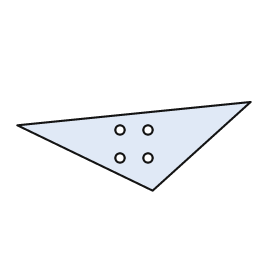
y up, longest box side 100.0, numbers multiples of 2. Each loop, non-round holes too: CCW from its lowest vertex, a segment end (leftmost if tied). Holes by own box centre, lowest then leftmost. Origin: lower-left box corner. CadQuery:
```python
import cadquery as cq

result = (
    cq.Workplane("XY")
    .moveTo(58.0, 0.0)
    .lineTo(100.0, 38.0)
    .lineTo(0.0, 28.0)
    .close()
    .moveTo(44.0, 14.0)
    .circle(2.0)
    .moveTo(56.0, 14.0)
    .circle(2.0)
    .moveTo(44.0, 26.0)
    .circle(2.0)
    .moveTo(56.0, 26.0)
    .circle(2.0)
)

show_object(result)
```